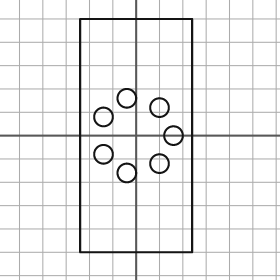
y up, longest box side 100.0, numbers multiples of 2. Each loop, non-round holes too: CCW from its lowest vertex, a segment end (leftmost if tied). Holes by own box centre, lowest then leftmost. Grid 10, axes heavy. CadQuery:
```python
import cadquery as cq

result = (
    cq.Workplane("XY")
    .moveTo(-24.0, -50.0)
    .lineTo(24.0, -50.0)
    .lineTo(24.0, 50.0)
    .lineTo(-24.0, 50.0)
    .close()
    .moveTo(-4.0, -16.0)
    .circle(4.0)
    .moveTo(10.0, -12.0)
    .circle(4.0)
    .moveTo(-14.0, -8.0)
    .circle(4.0)
    .moveTo(16.0, 0.0)
    .circle(4.0)
    .moveTo(-14.0, 8.0)
    .circle(4.0)
    .moveTo(10.0, 12.0)
    .circle(4.0)
    .moveTo(-4.0, 16.0)
    .circle(4.0)
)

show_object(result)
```